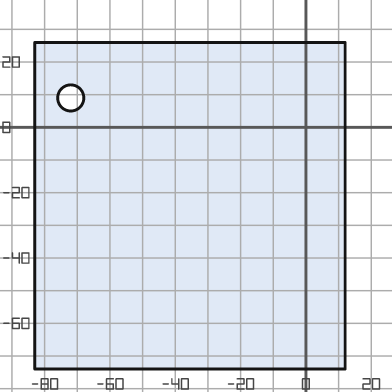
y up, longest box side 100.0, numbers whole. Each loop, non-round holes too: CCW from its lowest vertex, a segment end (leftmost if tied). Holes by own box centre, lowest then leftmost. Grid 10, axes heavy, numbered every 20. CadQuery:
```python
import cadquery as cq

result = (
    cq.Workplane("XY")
    .moveTo(-83.0, -74.0)
    .lineTo(12.0, -74.0)
    .lineTo(12.0, 26.0)
    .lineTo(-83.0, 26.0)
    .close()
    .moveTo(-72.0, 9.0)
    .circle(4.0)
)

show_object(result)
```